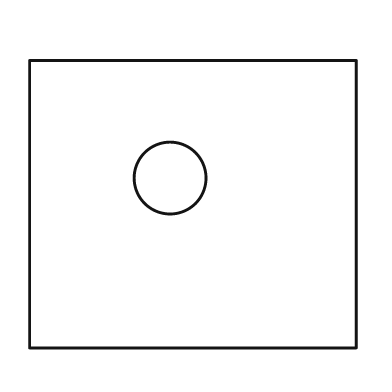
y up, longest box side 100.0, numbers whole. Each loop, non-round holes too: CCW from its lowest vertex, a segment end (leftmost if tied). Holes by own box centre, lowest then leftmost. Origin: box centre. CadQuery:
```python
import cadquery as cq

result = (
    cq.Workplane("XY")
    .moveTo(-50.0, -44.0)
    .lineTo(50.0, -44.0)
    .lineTo(50.0, 44.0)
    .lineTo(-50.0, 44.0)
    .close()
    .moveTo(-7.0, 8.0)
    .circle(11.0)
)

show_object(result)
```